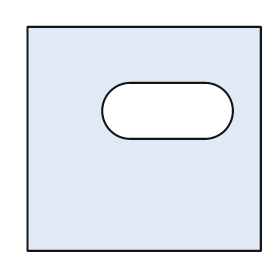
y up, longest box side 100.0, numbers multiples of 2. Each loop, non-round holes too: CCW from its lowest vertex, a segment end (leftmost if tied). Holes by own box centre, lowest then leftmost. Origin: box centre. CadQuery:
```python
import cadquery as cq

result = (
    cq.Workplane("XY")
    .moveTo(-50.0, -48.0)
    .lineTo(50.0, -48.0)
    .lineTo(50.0, 48.0)
    .lineTo(-50.0, 48.0)
    .close()
    .moveTo(-6.0, 0.0)
    .lineTo(26.0, 0.0)
    .threePointArc((38.0, 12.0), (26.0, 24.0))
    .lineTo(-6.0, 24.0)
    .threePointArc((-18.0, 12.0), (-6.0, 0.0))
    .close()
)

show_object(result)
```